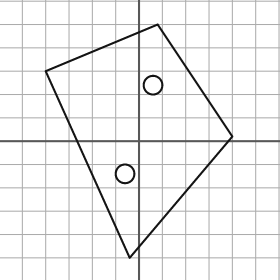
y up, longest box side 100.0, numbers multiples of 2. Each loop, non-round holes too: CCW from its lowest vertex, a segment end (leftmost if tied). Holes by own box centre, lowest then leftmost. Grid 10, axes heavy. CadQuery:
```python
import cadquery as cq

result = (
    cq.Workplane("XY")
    .moveTo(-4.0, -50.0)
    .lineTo(40.0, 2.0)
    .lineTo(8.0, 50.0)
    .lineTo(-40.0, 30.0)
    .close()
    .moveTo(-6.0, -14.0)
    .circle(4.0)
    .moveTo(6.0, 24.0)
    .circle(4.0)
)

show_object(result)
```